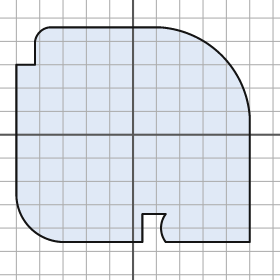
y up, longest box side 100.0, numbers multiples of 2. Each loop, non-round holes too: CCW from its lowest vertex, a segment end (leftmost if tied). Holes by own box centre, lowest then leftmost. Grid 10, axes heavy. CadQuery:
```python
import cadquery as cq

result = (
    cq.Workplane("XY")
    .moveTo(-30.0, -46.0)
    .lineTo(4.0, -46.0)
    .lineTo(4.0, -34.0)
    .lineTo(14.0, -34.0)
    .threePointArc((12.0, -40.0), (14.0, -46.0))
    .lineTo(50.0, -46.0)
    .lineTo(50.0, 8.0)
    .threePointArc((38.0, 34.0), (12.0, 46.0))
    .lineTo(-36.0, 46.0)
    .threePointArc((-40.0, 44.0), (-42.0, 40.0))
    .lineTo(-42.0, 30.0)
    .lineTo(-50.0, 30.0)
    .lineTo(-50.0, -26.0)
    .threePointArc((-44.0, -40.0), (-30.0, -46.0))
    .close()
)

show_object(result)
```